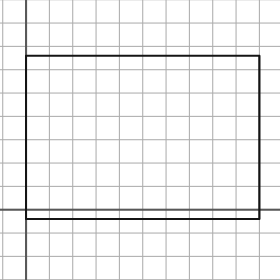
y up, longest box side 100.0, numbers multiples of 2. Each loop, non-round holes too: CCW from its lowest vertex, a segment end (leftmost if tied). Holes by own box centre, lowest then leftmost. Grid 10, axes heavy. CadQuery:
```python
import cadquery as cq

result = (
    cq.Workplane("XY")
    .moveTo(0.0, -4.0)
    .lineTo(100.0, -4.0)
    .lineTo(100.0, 66.0)
    .lineTo(0.0, 66.0)
    .close()
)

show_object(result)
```